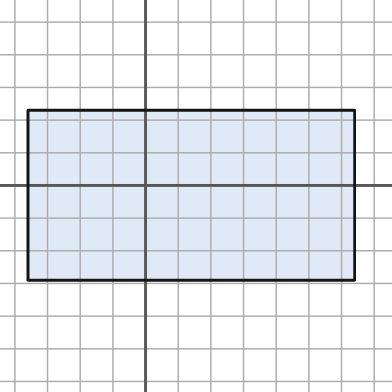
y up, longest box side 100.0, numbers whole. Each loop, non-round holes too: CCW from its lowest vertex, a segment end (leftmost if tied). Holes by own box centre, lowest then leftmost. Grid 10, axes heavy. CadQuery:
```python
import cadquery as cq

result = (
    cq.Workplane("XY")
    .moveTo(-36.0, -29.0)
    .lineTo(64.0, -29.0)
    .lineTo(64.0, 23.0)
    .lineTo(-36.0, 23.0)
    .close()
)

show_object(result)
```